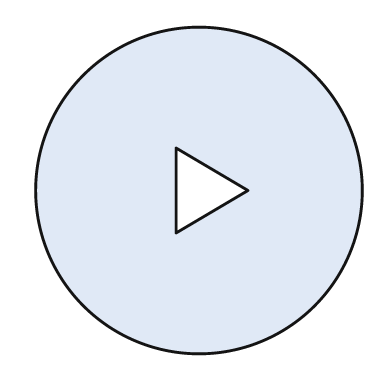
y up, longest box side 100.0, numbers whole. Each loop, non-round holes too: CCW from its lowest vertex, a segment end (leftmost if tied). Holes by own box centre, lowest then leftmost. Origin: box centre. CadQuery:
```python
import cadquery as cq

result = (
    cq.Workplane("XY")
    .moveTo(0.0, 0.0)
    .circle(50.0)
    .moveTo(-7.0, -13.0)
    .lineTo(15.0, 0.0)
    .lineTo(-7.0, 13.0)
    .close()
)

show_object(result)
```